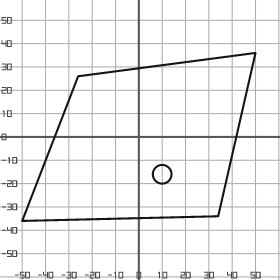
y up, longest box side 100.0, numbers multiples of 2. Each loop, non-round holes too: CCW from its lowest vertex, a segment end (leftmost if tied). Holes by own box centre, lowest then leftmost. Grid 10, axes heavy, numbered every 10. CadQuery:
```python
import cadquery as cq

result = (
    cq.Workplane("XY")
    .moveTo(-50.0, -36.0)
    .lineTo(34.0, -34.0)
    .lineTo(50.0, 36.0)
    .lineTo(-26.0, 26.0)
    .close()
    .moveTo(10.0, -16.0)
    .circle(4.0)
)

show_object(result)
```